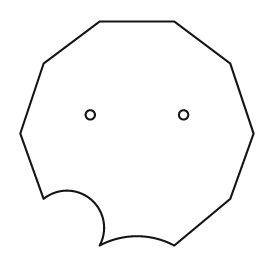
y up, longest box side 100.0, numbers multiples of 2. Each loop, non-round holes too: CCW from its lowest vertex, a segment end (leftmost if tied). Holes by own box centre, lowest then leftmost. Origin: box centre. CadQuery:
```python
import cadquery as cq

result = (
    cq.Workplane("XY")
    .moveTo(-16.0, -48.0)
    .threePointArc((0.0, -44.0), (16.0, -48.0))
    .lineTo(40.0, -28.0)
    .lineTo(50.0, 0.0)
    .lineTo(40.0, 30.0)
    .lineTo(16.0, 48.0)
    .lineTo(-16.0, 48.0)
    .lineTo(-40.0, 30.0)
    .lineTo(-50.0, 0.0)
    .lineTo(-40.0, -28.0)
    .threePointArc((-20.0, -28.0), (-16.0, -48.0))
    .close()
    .moveTo(-20.0, 8.0)
    .circle(2.0)
    .moveTo(20.0, 8.0)
    .circle(2.0)
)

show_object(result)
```